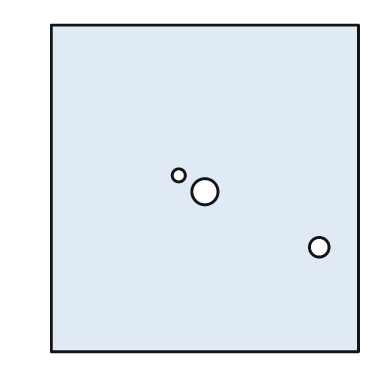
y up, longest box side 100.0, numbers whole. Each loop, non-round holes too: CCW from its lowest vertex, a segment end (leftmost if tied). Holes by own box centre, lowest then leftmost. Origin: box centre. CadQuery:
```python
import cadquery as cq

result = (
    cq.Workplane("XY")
    .moveTo(-47.0, -50.0)
    .lineTo(47.0, -50.0)
    .lineTo(47.0, 50.0)
    .lineTo(-47.0, 50.0)
    .close()
    .moveTo(35.0, -18.0)
    .circle(3.0)
    .moveTo(0.0, -1.0)
    .circle(4.0)
    .moveTo(-8.0, 4.0)
    .circle(2.0)
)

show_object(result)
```